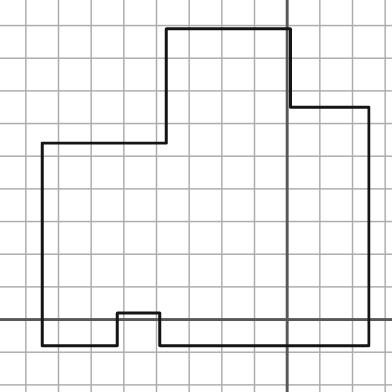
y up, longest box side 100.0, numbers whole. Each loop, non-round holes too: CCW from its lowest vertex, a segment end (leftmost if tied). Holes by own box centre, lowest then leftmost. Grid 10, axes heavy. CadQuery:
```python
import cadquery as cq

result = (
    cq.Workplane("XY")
    .moveTo(-75.0, -8.0)
    .lineTo(-52.0, -8.0)
    .lineTo(-52.0, 2.0)
    .lineTo(-39.0, 2.0)
    .lineTo(-39.0, -8.0)
    .lineTo(25.0, -8.0)
    .lineTo(25.0, 65.0)
    .lineTo(1.0, 65.0)
    .lineTo(1.0, 89.0)
    .lineTo(-37.0, 89.0)
    .lineTo(-37.0, 54.0)
    .lineTo(-75.0, 54.0)
    .close()
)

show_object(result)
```